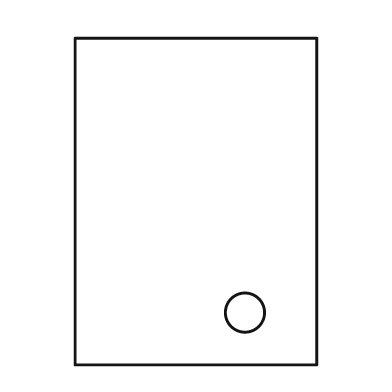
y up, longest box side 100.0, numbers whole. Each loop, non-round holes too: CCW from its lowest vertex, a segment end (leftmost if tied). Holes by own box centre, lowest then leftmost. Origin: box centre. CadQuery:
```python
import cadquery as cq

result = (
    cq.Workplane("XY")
    .moveTo(-37.0, -50.0)
    .lineTo(37.0, -50.0)
    .lineTo(37.0, 50.0)
    .lineTo(-37.0, 50.0)
    .close()
    .moveTo(15.0, -34.0)
    .circle(6.0)
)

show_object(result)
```